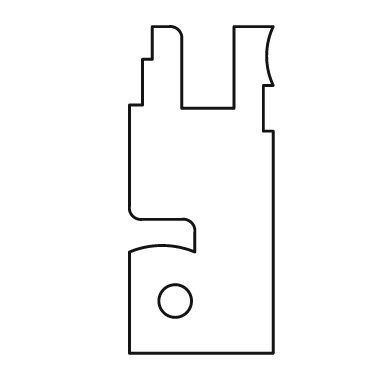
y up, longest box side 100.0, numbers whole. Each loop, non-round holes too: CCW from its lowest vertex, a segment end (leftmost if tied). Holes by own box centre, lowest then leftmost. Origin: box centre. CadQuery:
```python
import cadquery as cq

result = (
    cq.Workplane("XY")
    .moveTo(-22.0, -50.0)
    .lineTo(22.0, -50.0)
    .lineTo(22.0, 18.0)
    .lineTo(19.0, 18.0)
    .lineTo(19.0, 32.0)
    .lineTo(22.0, 32.0)
    .threePointArc((20.0, 41.0), (22.0, 50.0))
    .lineTo(10.0, 50.0)
    .lineTo(10.0, 25.0)
    .lineTo(-6.0, 25.0)
    .lineTo(-6.0, 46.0)
    .threePointArc((-7.0, 49.0), (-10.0, 50.0))
    .lineTo(-15.0, 50.0)
    .lineTo(-15.0, 40.0)
    .lineTo(-18.0, 40.0)
    .lineTo(-18.0, 26.0)
    .lineTo(-22.0, 26.0)
    .lineTo(-22.0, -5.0)
    .threePointArc((-21.0, -8.0), (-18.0, -9.0))
    .lineTo(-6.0, -9.0)
    .threePointArc((-3.0, -10.0), (-2.0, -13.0))
    .lineTo(-2.0, -19.0)
    .threePointArc((-12.0, -17.0), (-22.0, -19.0))
    .close()
    .moveTo(-8.0, -34.0)
    .circle(5.0)
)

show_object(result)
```